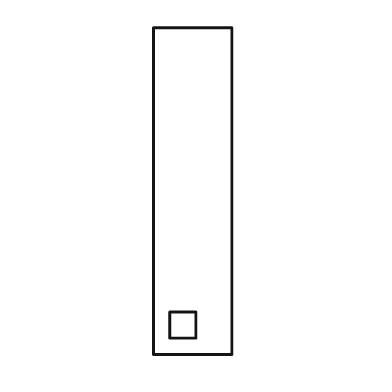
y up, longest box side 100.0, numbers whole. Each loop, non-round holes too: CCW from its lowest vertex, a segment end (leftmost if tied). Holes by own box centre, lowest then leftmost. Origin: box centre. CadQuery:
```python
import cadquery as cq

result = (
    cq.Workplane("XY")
    .moveTo(-12.0, -50.0)
    .lineTo(12.0, -50.0)
    .lineTo(12.0, 50.0)
    .lineTo(-12.0, 50.0)
    .close()
    .moveTo(-7.0, -45.0)
    .lineTo(1.0, -45.0)
    .lineTo(1.0, -37.0)
    .lineTo(-7.0, -37.0)
    .close()
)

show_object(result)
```